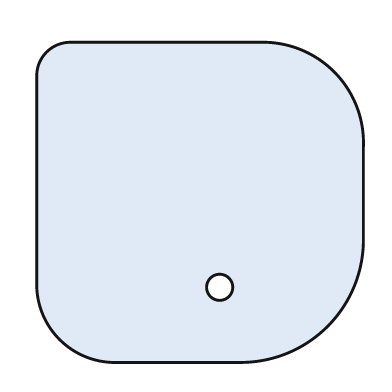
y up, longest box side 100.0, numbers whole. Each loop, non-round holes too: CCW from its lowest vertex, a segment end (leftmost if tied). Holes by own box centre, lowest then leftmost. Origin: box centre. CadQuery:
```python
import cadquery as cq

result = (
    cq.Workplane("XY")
    .moveTo(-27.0, -49.0)
    .lineTo(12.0, -49.0)
    .threePointArc((39.0, -38.0), (50.0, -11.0))
    .lineTo(50.0, 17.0)
    .threePointArc((41.0, 40.0), (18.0, 49.0))
    .lineTo(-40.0, 49.0)
    .threePointArc((-47.0, 46.0), (-50.0, 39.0))
    .lineTo(-50.0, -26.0)
    .threePointArc((-43.0, -42.0), (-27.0, -49.0))
    .close()
    .moveTo(6.0, -26.0)
    .circle(4.0)
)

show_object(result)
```